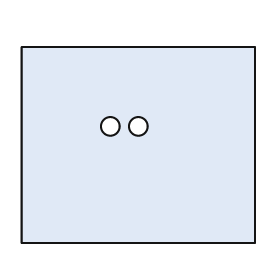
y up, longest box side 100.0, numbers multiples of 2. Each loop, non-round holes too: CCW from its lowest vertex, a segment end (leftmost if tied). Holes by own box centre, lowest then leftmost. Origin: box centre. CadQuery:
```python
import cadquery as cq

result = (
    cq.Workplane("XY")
    .moveTo(-50.0, -42.0)
    .lineTo(50.0, -42.0)
    .lineTo(50.0, 42.0)
    .lineTo(-50.0, 42.0)
    .close()
    .moveTo(-12.0, 8.0)
    .circle(4.0)
    .moveTo(0.0, 8.0)
    .circle(4.0)
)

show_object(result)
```